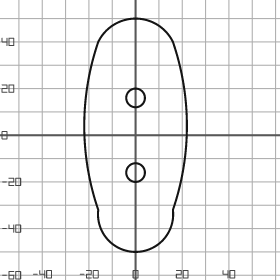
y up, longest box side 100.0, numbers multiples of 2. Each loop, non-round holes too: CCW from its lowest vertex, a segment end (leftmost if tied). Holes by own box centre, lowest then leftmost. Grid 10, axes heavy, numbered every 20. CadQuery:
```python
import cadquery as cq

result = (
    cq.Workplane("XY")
    .moveTo(-16.0, -32.0)
    .threePointArc((0.0, -50.0), (16.0, -32.0))
    .threePointArc((22.0, 4.0), (16.0, 40.0))
    .threePointArc((0.0, 50.0), (-16.0, 40.0))
    .threePointArc((-22.0, 4.0), (-16.0, -32.0))
    .close()
    .moveTo(0.0, -16.0)
    .circle(4.0)
    .moveTo(0.0, 16.0)
    .circle(4.0)
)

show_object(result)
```